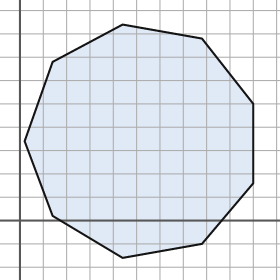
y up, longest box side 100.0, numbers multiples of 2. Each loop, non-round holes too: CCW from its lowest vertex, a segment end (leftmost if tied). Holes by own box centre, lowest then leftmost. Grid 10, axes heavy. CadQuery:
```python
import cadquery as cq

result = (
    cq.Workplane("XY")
    .moveTo(44.0, -16.0)
    .lineTo(78.0, -10.0)
    .lineTo(100.0, 16.0)
    .lineTo(100.0, 50.0)
    .lineTo(78.0, 78.0)
    .lineTo(44.0, 84.0)
    .lineTo(14.0, 68.0)
    .lineTo(2.0, 34.0)
    .lineTo(14.0, 2.0)
    .close()
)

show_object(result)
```